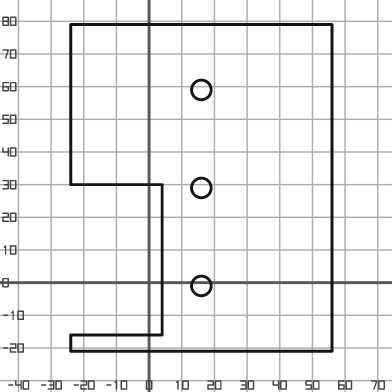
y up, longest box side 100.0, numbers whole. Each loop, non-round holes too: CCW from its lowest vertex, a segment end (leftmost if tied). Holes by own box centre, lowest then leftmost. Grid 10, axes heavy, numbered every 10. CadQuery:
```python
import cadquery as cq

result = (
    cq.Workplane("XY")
    .moveTo(-24.0, -21.0)
    .lineTo(56.0, -21.0)
    .lineTo(56.0, 79.0)
    .lineTo(-24.0, 79.0)
    .lineTo(-24.0, 30.0)
    .lineTo(4.0, 30.0)
    .lineTo(4.0, -16.0)
    .lineTo(-24.0, -16.0)
    .close()
    .moveTo(16.0, -1.0)
    .circle(3.0)
    .moveTo(16.0, 29.0)
    .circle(3.0)
    .moveTo(16.0, 59.0)
    .circle(3.0)
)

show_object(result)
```